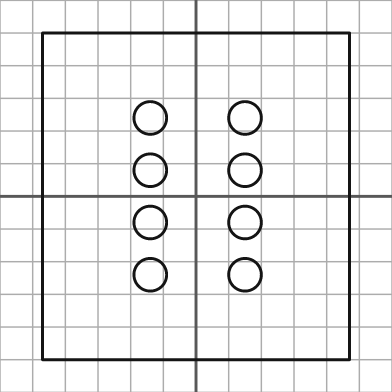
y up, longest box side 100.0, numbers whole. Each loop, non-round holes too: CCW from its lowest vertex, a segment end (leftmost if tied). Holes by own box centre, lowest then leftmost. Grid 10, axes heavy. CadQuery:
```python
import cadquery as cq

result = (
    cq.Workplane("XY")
    .moveTo(-47.0, -50.0)
    .lineTo(47.0, -50.0)
    .lineTo(47.0, 50.0)
    .lineTo(-47.0, 50.0)
    .close()
    .moveTo(-14.0, -24.0)
    .circle(5.0)
    .moveTo(15.0, -24.0)
    .circle(5.0)
    .moveTo(-14.0, -8.0)
    .circle(5.0)
    .moveTo(15.0, -8.0)
    .circle(5.0)
    .moveTo(-14.0, 8.0)
    .circle(5.0)
    .moveTo(15.0, 8.0)
    .circle(5.0)
    .moveTo(-14.0, 24.0)
    .circle(5.0)
    .moveTo(15.0, 24.0)
    .circle(5.0)
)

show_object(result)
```